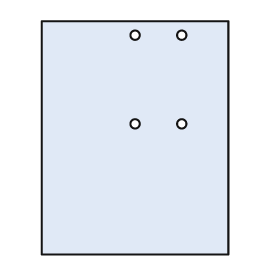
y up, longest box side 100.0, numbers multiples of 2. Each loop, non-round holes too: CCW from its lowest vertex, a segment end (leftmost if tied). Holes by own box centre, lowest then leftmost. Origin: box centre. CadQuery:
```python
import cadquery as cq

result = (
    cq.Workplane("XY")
    .moveTo(-40.0, -50.0)
    .lineTo(40.0, -50.0)
    .lineTo(40.0, 50.0)
    .lineTo(-40.0, 50.0)
    .close()
    .moveTo(0.0, 6.0)
    .circle(2.0)
    .moveTo(20.0, 6.0)
    .circle(2.0)
    .moveTo(0.0, 44.0)
    .circle(2.0)
    .moveTo(20.0, 44.0)
    .circle(2.0)
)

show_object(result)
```